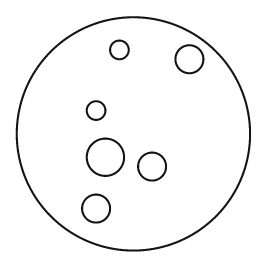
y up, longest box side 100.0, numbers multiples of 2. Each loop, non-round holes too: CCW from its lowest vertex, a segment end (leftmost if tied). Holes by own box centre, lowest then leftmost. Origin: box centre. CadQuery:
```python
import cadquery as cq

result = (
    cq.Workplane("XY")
    .moveTo(0.0, 0.0)
    .circle(50.0)
    .moveTo(-16.0, -32.0)
    .circle(6.0)
    .moveTo(8.0, -14.0)
    .circle(6.0)
    .moveTo(-12.0, -10.0)
    .circle(8.0)
    .moveTo(-16.0, 10.0)
    .circle(4.0)
    .moveTo(24.0, 32.0)
    .circle(6.0)
    .moveTo(-6.0, 36.0)
    .circle(4.0)
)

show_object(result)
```